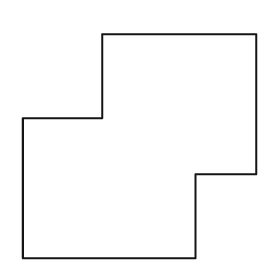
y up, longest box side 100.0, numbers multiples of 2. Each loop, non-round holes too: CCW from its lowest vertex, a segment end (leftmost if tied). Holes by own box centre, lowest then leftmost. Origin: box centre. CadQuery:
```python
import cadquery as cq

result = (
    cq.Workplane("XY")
    .moveTo(-50.0, -48.0)
    .lineTo(24.0, -48.0)
    .lineTo(24.0, -12.0)
    .lineTo(50.0, -12.0)
    .lineTo(50.0, 48.0)
    .lineTo(-16.0, 48.0)
    .lineTo(-16.0, 12.0)
    .lineTo(-50.0, 12.0)
    .close()
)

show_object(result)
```